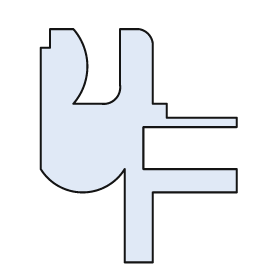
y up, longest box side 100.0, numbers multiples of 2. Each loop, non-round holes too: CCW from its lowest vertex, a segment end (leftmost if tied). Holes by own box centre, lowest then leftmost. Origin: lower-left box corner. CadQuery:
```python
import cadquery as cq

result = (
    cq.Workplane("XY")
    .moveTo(36.0, 0.0)
    .lineTo(48.0, 0.0)
    .lineTo(48.0, 30.0)
    .lineTo(84.0, 30.0)
    .lineTo(84.0, 40.0)
    .lineTo(44.0, 40.0)
    .lineTo(44.0, 58.0)
    .lineTo(84.0, 58.0)
    .lineTo(84.0, 62.0)
    .lineTo(54.0, 62.0)
    .lineTo(54.0, 68.0)
    .lineTo(48.0, 68.0)
    .lineTo(48.0, 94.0)
    .threePointArc((46.0, 98.0), (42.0, 100.0))
    .lineTo(34.0, 100.0)
    .lineTo(34.0, 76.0)
    .threePointArc((32.0, 70.0), (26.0, 68.0))
    .lineTo(14.0, 68.0)
    .threePointArc((20.0, 84.0), (14.0, 100.0))
    .lineTo(4.0, 100.0)
    .lineTo(4.0, 92.0)
    .lineTo(0.0, 92.0)
    .lineTo(0.0, 40.0)
    .threePointArc((18.0, 30.0), (36.0, 40.0))
    .close()
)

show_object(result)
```